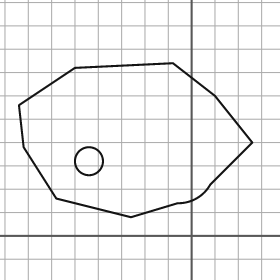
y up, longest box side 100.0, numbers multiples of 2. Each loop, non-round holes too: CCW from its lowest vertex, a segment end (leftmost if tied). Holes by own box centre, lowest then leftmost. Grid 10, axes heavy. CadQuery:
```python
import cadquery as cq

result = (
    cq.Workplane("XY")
    .moveTo(-26.0, 8.0)
    .lineTo(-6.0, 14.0)
    .threePointArc((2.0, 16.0), (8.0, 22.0))
    .lineTo(26.0, 40.0)
    .lineTo(10.0, 60.0)
    .lineTo(-8.0, 74.0)
    .lineTo(-50.0, 72.0)
    .lineTo(-74.0, 56.0)
    .lineTo(-72.0, 38.0)
    .lineTo(-58.0, 16.0)
    .close()
    .moveTo(-44.0, 32.0)
    .circle(6.0)
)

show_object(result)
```